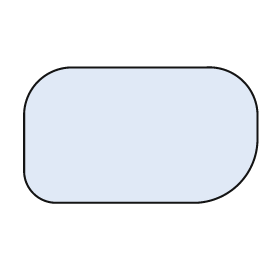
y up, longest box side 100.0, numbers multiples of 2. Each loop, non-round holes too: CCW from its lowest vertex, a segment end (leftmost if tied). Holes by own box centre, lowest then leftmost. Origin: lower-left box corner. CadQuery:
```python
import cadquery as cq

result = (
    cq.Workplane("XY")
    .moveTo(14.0, 0.0)
    .lineTo(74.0, 0.0)
    .threePointArc((92.0, 8.0), (100.0, 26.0))
    .lineTo(100.0, 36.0)
    .threePointArc((94.0, 52.0), (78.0, 58.0))
    .lineTo(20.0, 58.0)
    .threePointArc((6.0, 52.0), (0.0, 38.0))
    .lineTo(0.0, 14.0)
    .threePointArc((4.0, 4.0), (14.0, 0.0))
    .close()
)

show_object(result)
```